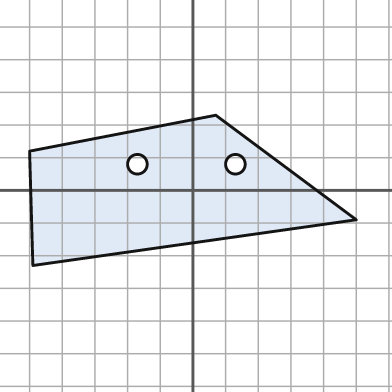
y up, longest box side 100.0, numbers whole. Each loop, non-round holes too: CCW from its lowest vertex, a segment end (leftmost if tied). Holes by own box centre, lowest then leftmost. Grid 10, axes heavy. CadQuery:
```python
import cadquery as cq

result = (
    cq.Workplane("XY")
    .moveTo(-49.0, -23.0)
    .lineTo(50.0, -9.0)
    .lineTo(7.0, 23.0)
    .lineTo(-50.0, 12.0)
    .close()
    .moveTo(-17.0, 8.0)
    .circle(3.0)
    .moveTo(13.0, 8.0)
    .circle(3.0)
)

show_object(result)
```